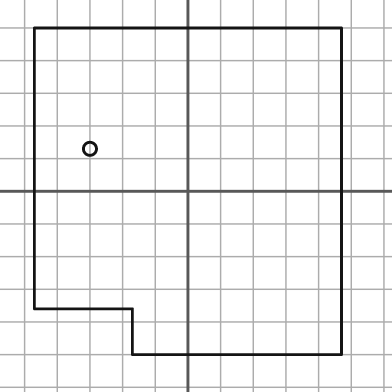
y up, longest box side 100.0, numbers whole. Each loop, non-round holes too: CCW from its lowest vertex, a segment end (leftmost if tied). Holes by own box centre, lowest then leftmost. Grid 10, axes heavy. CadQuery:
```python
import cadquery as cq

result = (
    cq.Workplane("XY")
    .moveTo(-17.0, -50.0)
    .lineTo(47.0, -50.0)
    .lineTo(47.0, 50.0)
    .lineTo(-47.0, 50.0)
    .lineTo(-47.0, -36.0)
    .lineTo(-17.0, -36.0)
    .close()
    .moveTo(-30.0, 13.0)
    .circle(2.0)
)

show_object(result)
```